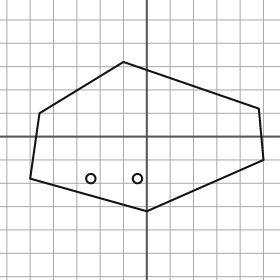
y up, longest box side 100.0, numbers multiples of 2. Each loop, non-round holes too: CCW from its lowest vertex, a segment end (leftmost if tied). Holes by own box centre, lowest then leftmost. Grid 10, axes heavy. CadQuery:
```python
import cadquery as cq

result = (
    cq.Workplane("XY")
    .moveTo(0.0, -32.0)
    .lineTo(50.0, -10.0)
    .lineTo(48.0, 12.0)
    .lineTo(-10.0, 32.0)
    .lineTo(-46.0, 10.0)
    .lineTo(-50.0, -18.0)
    .close()
    .moveTo(-24.0, -18.0)
    .circle(2.0)
    .moveTo(-4.0, -18.0)
    .circle(2.0)
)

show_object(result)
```